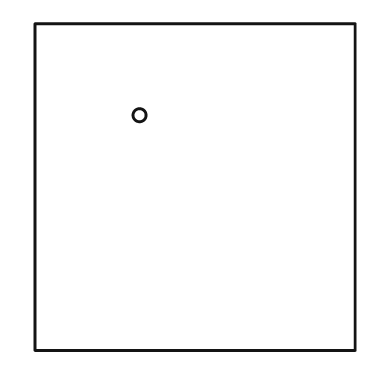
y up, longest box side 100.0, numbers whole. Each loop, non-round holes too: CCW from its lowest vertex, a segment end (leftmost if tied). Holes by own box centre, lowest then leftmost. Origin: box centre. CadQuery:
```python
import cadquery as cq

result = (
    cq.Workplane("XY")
    .moveTo(-49.0, -50.0)
    .lineTo(49.0, -50.0)
    .lineTo(49.0, 50.0)
    .lineTo(-49.0, 50.0)
    .close()
    .moveTo(-17.0, 22.0)
    .circle(2.0)
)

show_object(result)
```